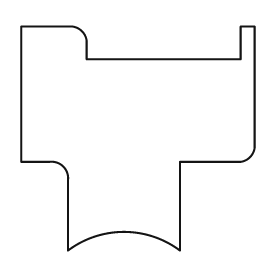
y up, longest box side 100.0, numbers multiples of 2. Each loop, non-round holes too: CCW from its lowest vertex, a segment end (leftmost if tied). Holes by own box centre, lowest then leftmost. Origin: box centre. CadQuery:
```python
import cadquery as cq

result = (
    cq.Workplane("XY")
    .moveTo(-30.0, -48.0)
    .threePointArc((-6.0, -40.0), (18.0, -48.0))
    .lineTo(18.0, -10.0)
    .lineTo(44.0, -10.0)
    .threePointArc((48.0, -8.0), (50.0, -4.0))
    .lineTo(50.0, 48.0)
    .lineTo(44.0, 48.0)
    .lineTo(44.0, 34.0)
    .lineTo(-22.0, 34.0)
    .lineTo(-22.0, 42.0)
    .threePointArc((-24.0, 46.0), (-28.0, 48.0))
    .lineTo(-50.0, 48.0)
    .lineTo(-50.0, -10.0)
    .lineTo(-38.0, -10.0)
    .threePointArc((-32.0, -12.0), (-30.0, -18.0))
    .close()
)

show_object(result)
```